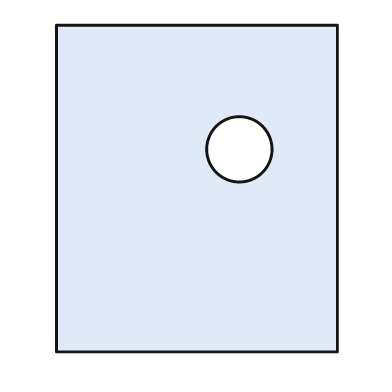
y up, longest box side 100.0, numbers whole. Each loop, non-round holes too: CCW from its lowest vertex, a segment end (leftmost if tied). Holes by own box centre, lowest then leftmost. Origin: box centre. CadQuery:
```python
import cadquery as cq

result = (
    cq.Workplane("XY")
    .moveTo(-43.0, -50.0)
    .lineTo(43.0, -50.0)
    .lineTo(43.0, 50.0)
    .lineTo(-43.0, 50.0)
    .close()
    .moveTo(13.0, 12.0)
    .circle(10.0)
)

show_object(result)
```